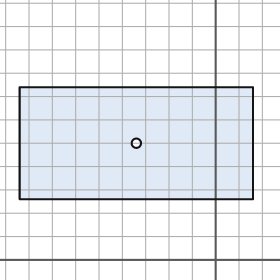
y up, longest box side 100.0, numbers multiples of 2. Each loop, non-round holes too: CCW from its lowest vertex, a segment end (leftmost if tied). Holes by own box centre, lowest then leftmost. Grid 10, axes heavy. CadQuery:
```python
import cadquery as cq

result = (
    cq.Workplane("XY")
    .moveTo(-84.0, 26.0)
    .lineTo(16.0, 26.0)
    .lineTo(16.0, 74.0)
    .lineTo(-84.0, 74.0)
    .close()
    .moveTo(-34.0, 50.0)
    .circle(2.0)
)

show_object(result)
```